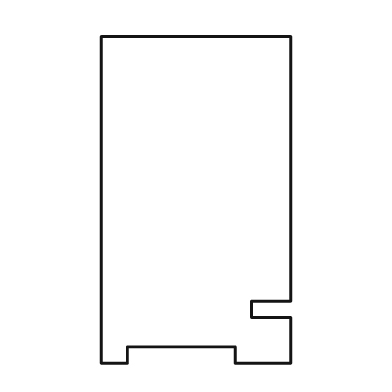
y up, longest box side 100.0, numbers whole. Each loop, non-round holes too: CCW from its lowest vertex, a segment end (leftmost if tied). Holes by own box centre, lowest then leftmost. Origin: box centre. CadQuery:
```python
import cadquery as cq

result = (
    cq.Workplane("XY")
    .moveTo(-29.0, -50.0)
    .lineTo(-21.0, -50.0)
    .lineTo(-21.0, -45.0)
    .lineTo(12.0, -45.0)
    .lineTo(12.0, -50.0)
    .lineTo(29.0, -50.0)
    .lineTo(29.0, -36.0)
    .lineTo(17.0, -36.0)
    .lineTo(17.0, -31.0)
    .lineTo(29.0, -31.0)
    .lineTo(29.0, 50.0)
    .lineTo(-29.0, 50.0)
    .close()
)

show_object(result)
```